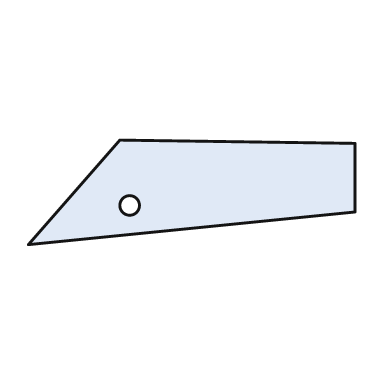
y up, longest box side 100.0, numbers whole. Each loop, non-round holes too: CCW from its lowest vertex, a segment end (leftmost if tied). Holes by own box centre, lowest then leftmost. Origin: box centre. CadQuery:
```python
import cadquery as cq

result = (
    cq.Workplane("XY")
    .moveTo(-50.0, -16.0)
    .lineTo(50.0, -6.0)
    .lineTo(50.0, 15.0)
    .lineTo(-22.0, 16.0)
    .close()
    .moveTo(-19.0, -4.0)
    .circle(3.0)
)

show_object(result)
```